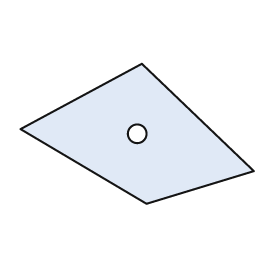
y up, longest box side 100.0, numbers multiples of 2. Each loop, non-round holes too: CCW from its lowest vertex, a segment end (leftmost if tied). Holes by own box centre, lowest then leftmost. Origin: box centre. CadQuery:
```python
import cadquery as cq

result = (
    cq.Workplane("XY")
    .moveTo(4.0, -30.0)
    .lineTo(50.0, -16.0)
    .lineTo(2.0, 30.0)
    .lineTo(-50.0, 2.0)
    .close()
    .moveTo(0.0, 0.0)
    .circle(4.0)
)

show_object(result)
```